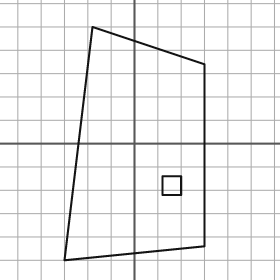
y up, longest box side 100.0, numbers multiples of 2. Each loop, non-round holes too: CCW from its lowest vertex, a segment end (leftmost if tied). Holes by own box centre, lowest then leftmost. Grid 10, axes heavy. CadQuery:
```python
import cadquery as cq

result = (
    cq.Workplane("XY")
    .moveTo(-30.0, -50.0)
    .lineTo(30.0, -44.0)
    .lineTo(30.0, 34.0)
    .lineTo(-18.0, 50.0)
    .close()
    .moveTo(12.0, -22.0)
    .lineTo(20.0, -22.0)
    .lineTo(20.0, -14.0)
    .lineTo(12.0, -14.0)
    .close()
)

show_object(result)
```